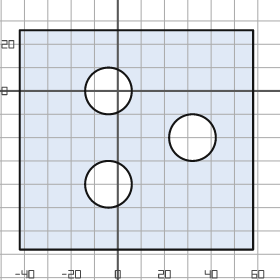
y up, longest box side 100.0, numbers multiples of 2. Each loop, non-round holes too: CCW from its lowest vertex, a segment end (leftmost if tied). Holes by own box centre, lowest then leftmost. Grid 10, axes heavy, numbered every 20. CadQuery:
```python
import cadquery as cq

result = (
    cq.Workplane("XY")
    .moveTo(-42.0, -68.0)
    .lineTo(58.0, -68.0)
    .lineTo(58.0, 26.0)
    .lineTo(-42.0, 26.0)
    .close()
    .moveTo(-4.0, -40.0)
    .circle(10.0)
    .moveTo(32.0, -20.0)
    .circle(10.0)
    .moveTo(-4.0, 0.0)
    .circle(10.0)
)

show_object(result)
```